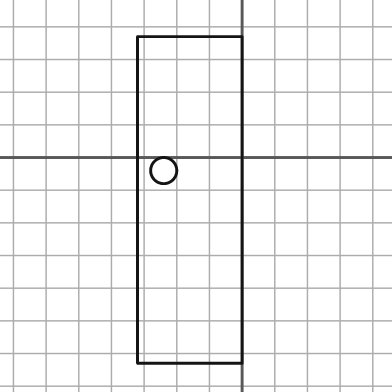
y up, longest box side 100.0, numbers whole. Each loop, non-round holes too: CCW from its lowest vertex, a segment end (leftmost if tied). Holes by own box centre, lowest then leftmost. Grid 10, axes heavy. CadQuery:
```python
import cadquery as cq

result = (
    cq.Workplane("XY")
    .moveTo(-32.0, -63.0)
    .lineTo(0.0, -63.0)
    .lineTo(0.0, 37.0)
    .lineTo(-32.0, 37.0)
    .close()
    .moveTo(-24.0, -4.0)
    .circle(4.0)
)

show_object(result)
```